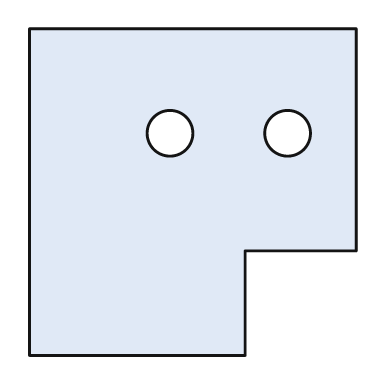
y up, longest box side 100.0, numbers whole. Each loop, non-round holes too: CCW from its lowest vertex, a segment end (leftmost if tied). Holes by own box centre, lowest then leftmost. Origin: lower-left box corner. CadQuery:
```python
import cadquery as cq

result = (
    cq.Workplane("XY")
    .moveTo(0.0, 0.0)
    .lineTo(66.0, 0.0)
    .lineTo(66.0, 32.0)
    .lineTo(100.0, 32.0)
    .lineTo(100.0, 100.0)
    .lineTo(0.0, 100.0)
    .close()
    .moveTo(43.0, 68.0)
    .circle(7.0)
    .moveTo(79.0, 68.0)
    .circle(7.0)
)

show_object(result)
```